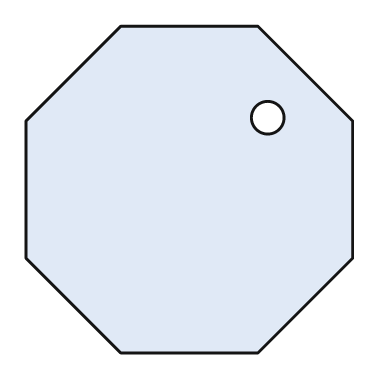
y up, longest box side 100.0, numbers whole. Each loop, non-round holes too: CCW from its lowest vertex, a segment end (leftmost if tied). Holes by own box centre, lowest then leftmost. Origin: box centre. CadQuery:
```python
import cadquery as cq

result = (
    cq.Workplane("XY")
    .moveTo(-21.0, -50.0)
    .lineTo(21.0, -50.0)
    .lineTo(50.0, -21.0)
    .lineTo(50.0, 21.0)
    .lineTo(21.0, 50.0)
    .lineTo(-21.0, 50.0)
    .lineTo(-50.0, 21.0)
    .lineTo(-50.0, -21.0)
    .close()
    .moveTo(24.0, 22.0)
    .circle(5.0)
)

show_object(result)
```